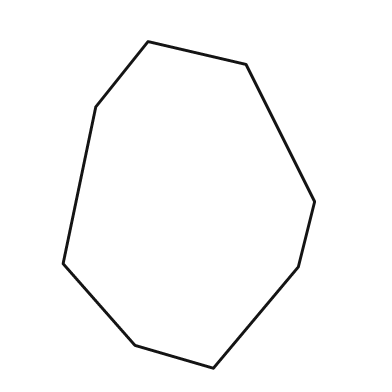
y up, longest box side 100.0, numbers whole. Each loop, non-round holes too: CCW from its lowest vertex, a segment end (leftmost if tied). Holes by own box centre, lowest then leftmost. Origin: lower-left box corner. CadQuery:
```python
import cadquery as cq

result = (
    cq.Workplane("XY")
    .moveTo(46.0, 0.0)
    .lineTo(72.0, 31.0)
    .lineTo(77.0, 51.0)
    .lineTo(56.0, 93.0)
    .lineTo(26.0, 100.0)
    .lineTo(10.0, 80.0)
    .lineTo(0.0, 32.0)
    .lineTo(22.0, 7.0)
    .close()
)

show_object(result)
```